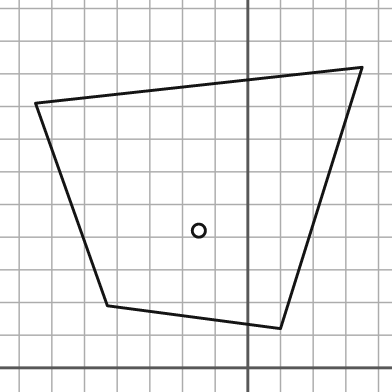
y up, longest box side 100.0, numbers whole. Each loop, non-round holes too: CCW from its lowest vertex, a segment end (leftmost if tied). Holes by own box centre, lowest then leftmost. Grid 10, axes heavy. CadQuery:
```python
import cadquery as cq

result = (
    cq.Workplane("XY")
    .moveTo(10.0, 12.0)
    .lineTo(35.0, 92.0)
    .lineTo(-65.0, 81.0)
    .lineTo(-43.0, 19.0)
    .close()
    .moveTo(-15.0, 42.0)
    .circle(2.0)
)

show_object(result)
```